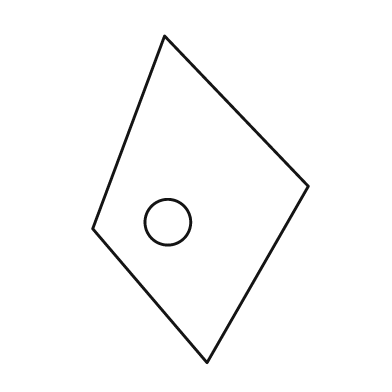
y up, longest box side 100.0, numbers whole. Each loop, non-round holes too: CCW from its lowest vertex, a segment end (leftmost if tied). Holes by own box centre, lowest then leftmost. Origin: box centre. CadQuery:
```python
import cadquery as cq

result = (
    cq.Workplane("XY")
    .moveTo(2.0, -50.0)
    .lineTo(33.0, 4.0)
    .lineTo(-11.0, 50.0)
    .lineTo(-33.0, -9.0)
    .close()
    .moveTo(-10.0, -7.0)
    .circle(7.0)
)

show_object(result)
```